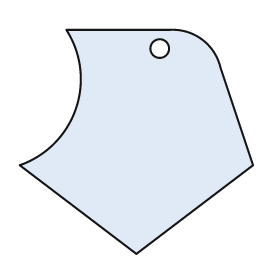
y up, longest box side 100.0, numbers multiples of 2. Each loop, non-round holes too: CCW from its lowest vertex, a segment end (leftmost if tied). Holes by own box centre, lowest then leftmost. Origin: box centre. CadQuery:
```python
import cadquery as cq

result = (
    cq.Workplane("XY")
    .moveTo(0.0, -48.0)
    .lineTo(50.0, -10.0)
    .lineTo(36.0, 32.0)
    .threePointArc((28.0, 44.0), (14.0, 48.0))
    .lineTo(-30.0, 48.0)
    .threePointArc((-26.0, 14.0), (-50.0, -10.0))
    .close()
    .moveTo(10.0, 40.0)
    .circle(4.0)
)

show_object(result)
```